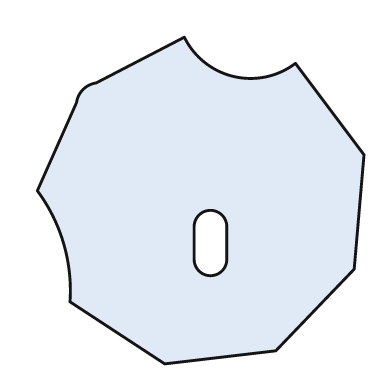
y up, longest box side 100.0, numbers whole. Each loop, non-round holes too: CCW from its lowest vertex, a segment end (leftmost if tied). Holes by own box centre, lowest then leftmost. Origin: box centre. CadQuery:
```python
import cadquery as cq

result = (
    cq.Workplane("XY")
    .moveTo(-11.0, -50.0)
    .lineTo(23.0, -46.0)
    .lineTo(47.0, -21.0)
    .lineTo(50.0, 14.0)
    .lineTo(29.0, 42.0)
    .threePointArc((10.0, 38.0), (-5.0, 50.0))
    .lineTo(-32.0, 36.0)
    .threePointArc((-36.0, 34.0), (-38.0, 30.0))
    .lineTo(-50.0, 3.0)
    .threePointArc((-42.0, -13.0), (-40.0, -31.0))
    .close()
    .moveTo(-2.0, -18.0)
    .threePointArc((3.0, -23.0), (8.0, -18.0))
    .lineTo(8.0, -8.0)
    .threePointArc((3.0, -3.0), (-2.0, -8.0))
    .close()
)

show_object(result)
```